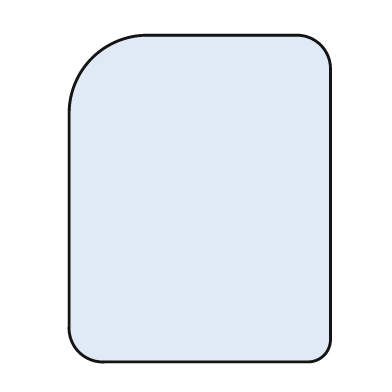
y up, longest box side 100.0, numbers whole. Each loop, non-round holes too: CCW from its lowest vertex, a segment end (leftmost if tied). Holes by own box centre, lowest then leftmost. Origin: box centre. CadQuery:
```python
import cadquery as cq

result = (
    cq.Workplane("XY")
    .moveTo(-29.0, -50.0)
    .lineTo(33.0, -50.0)
    .threePointArc((38.0, -48.0), (40.0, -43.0))
    .lineTo(40.0, 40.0)
    .threePointArc((37.0, 47.0), (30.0, 50.0))
    .lineTo(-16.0, 50.0)
    .threePointArc((-33.0, 43.0), (-40.0, 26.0))
    .lineTo(-40.0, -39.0)
    .threePointArc((-37.0, -47.0), (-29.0, -50.0))
    .close()
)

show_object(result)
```